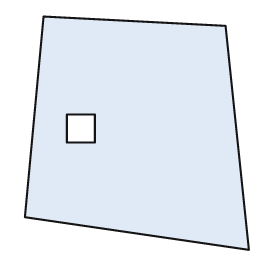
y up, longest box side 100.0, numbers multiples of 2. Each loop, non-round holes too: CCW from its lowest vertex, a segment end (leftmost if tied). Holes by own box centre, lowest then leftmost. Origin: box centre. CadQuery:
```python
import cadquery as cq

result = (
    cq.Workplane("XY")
    .moveTo(48.0, -50.0)
    .lineTo(38.0, 46.0)
    .lineTo(-40.0, 50.0)
    .lineTo(-48.0, -36.0)
    .close()
    .moveTo(-30.0, -4.0)
    .lineTo(-18.0, -4.0)
    .lineTo(-18.0, 8.0)
    .lineTo(-30.0, 8.0)
    .close()
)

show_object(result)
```